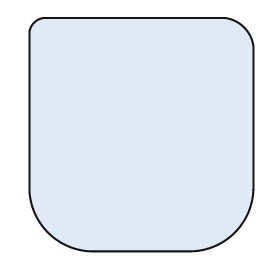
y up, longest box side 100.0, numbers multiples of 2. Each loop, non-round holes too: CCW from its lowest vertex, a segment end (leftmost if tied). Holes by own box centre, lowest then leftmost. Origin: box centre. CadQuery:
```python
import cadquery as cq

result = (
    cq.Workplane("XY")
    .moveTo(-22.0, -50.0)
    .lineTo(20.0, -50.0)
    .threePointArc((40.0, -42.0), (48.0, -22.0))
    .lineTo(48.0, 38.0)
    .threePointArc((44.0, 46.0), (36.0, 50.0))
    .lineTo(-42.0, 50.0)
    .threePointArc((-46.0, 48.0), (-48.0, 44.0))
    .lineTo(-48.0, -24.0)
    .threePointArc((-40.0, -42.0), (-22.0, -50.0))
    .close()
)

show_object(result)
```